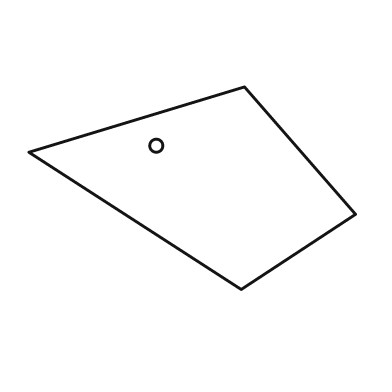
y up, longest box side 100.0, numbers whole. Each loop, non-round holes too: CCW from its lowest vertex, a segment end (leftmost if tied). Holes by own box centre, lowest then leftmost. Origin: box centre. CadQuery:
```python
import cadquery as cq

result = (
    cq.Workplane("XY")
    .moveTo(15.0, -31.0)
    .lineTo(50.0, -8.0)
    .lineTo(16.0, 31.0)
    .lineTo(-50.0, 11.0)
    .close()
    .moveTo(-11.0, 13.0)
    .circle(2.0)
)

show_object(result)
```